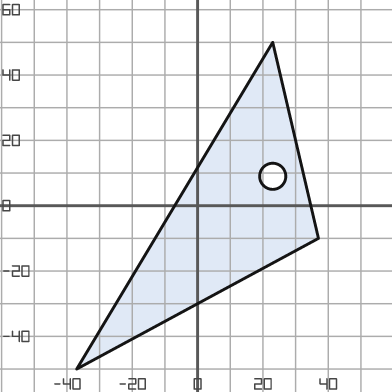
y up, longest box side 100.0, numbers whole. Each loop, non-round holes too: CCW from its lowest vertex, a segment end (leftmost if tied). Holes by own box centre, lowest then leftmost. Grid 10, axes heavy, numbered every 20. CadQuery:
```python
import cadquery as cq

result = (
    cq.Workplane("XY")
    .moveTo(-37.0, -50.0)
    .lineTo(37.0, -10.0)
    .lineTo(23.0, 50.0)
    .close()
    .moveTo(23.0, 9.0)
    .circle(4.0)
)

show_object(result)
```